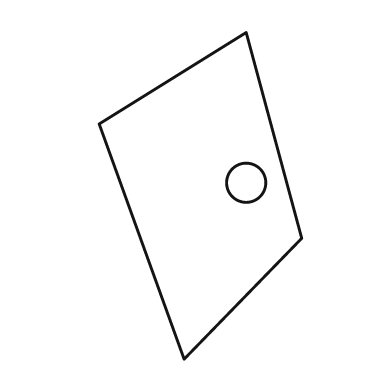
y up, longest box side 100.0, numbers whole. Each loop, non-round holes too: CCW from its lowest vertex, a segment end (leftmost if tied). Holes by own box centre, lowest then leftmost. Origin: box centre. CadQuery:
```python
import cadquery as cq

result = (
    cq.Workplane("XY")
    .moveTo(-5.0, -50.0)
    .lineTo(31.0, -13.0)
    .lineTo(14.0, 50.0)
    .lineTo(-31.0, 22.0)
    .close()
    .moveTo(14.0, 4.0)
    .circle(6.0)
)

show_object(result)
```